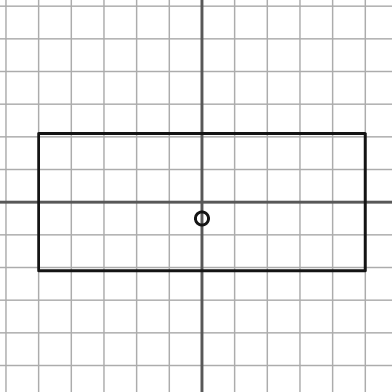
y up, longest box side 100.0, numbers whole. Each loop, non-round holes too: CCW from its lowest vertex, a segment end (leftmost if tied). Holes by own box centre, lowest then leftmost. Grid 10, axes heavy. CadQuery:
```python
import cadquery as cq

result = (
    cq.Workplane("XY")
    .moveTo(-50.0, -21.0)
    .lineTo(50.0, -21.0)
    .lineTo(50.0, 21.0)
    .lineTo(-50.0, 21.0)
    .close()
    .moveTo(0.0, -5.0)
    .circle(2.0)
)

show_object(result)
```